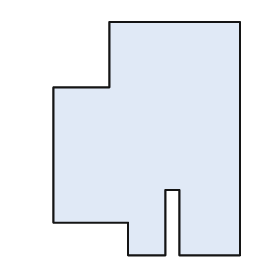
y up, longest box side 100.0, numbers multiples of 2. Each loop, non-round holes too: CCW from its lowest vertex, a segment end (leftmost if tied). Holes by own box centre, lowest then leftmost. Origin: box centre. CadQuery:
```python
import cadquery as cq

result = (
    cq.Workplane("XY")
    .moveTo(-8.0, -50.0)
    .lineTo(8.0, -50.0)
    .lineTo(8.0, -22.0)
    .lineTo(14.0, -22.0)
    .lineTo(14.0, -50.0)
    .lineTo(40.0, -50.0)
    .lineTo(40.0, 50.0)
    .lineTo(-16.0, 50.0)
    .lineTo(-16.0, 22.0)
    .lineTo(-40.0, 22.0)
    .lineTo(-40.0, -36.0)
    .lineTo(-8.0, -36.0)
    .close()
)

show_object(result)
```